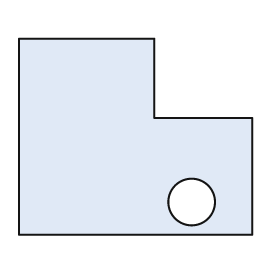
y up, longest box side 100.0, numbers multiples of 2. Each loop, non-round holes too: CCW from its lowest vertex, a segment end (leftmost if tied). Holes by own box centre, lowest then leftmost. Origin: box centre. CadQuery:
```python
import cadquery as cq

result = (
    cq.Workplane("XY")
    .moveTo(-50.0, -42.0)
    .lineTo(50.0, -42.0)
    .lineTo(50.0, 8.0)
    .lineTo(8.0, 8.0)
    .lineTo(8.0, 42.0)
    .lineTo(-50.0, 42.0)
    .close()
    .moveTo(24.0, -28.0)
    .circle(10.0)
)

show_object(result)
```